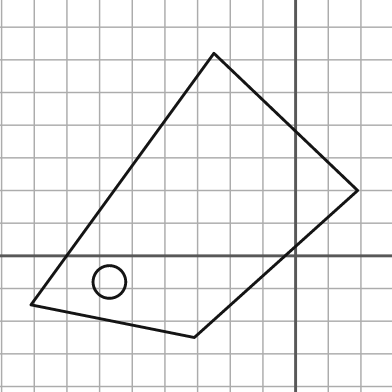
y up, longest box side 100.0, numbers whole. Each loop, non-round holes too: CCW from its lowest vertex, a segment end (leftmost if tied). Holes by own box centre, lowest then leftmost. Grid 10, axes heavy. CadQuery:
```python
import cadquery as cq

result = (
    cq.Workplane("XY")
    .moveTo(-31.0, -25.0)
    .lineTo(19.0, 20.0)
    .lineTo(-25.0, 62.0)
    .lineTo(-81.0, -15.0)
    .close()
    .moveTo(-57.0, -8.0)
    .circle(5.0)
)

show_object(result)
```